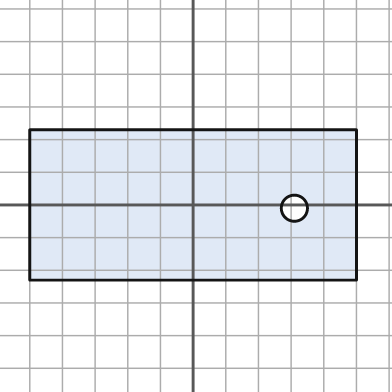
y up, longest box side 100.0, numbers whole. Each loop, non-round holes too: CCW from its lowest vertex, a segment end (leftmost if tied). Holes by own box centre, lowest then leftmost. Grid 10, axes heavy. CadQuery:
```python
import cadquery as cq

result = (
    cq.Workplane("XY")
    .moveTo(-50.0, -23.0)
    .lineTo(50.0, -23.0)
    .lineTo(50.0, 23.0)
    .lineTo(-50.0, 23.0)
    .close()
    .moveTo(31.0, -1.0)
    .circle(4.0)
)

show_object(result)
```